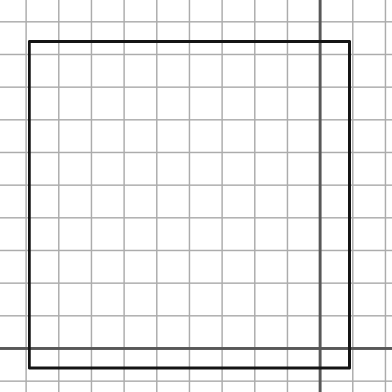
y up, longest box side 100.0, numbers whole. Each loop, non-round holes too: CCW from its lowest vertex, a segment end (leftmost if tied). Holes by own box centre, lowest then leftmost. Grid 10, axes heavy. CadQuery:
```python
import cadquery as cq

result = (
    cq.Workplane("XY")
    .moveTo(-89.0, -6.0)
    .lineTo(9.0, -6.0)
    .lineTo(9.0, 94.0)
    .lineTo(-89.0, 94.0)
    .close()
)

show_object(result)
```